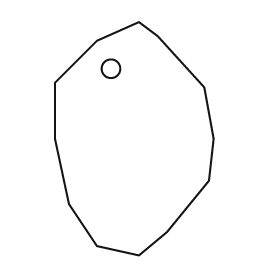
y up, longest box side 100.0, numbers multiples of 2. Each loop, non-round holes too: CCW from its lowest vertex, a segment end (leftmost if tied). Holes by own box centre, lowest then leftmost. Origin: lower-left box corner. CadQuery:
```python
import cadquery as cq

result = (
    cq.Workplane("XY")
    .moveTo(36.0, 0.0)
    .lineTo(48.0, 10.0)
    .lineTo(66.0, 32.0)
    .lineTo(68.0, 50.0)
    .lineTo(64.0, 72.0)
    .lineTo(44.0, 94.0)
    .lineTo(36.0, 100.0)
    .lineTo(18.0, 92.0)
    .lineTo(0.0, 74.0)
    .lineTo(0.0, 50.0)
    .lineTo(6.0, 22.0)
    .lineTo(18.0, 4.0)
    .close()
    .moveTo(24.0, 80.0)
    .circle(4.0)
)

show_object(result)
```